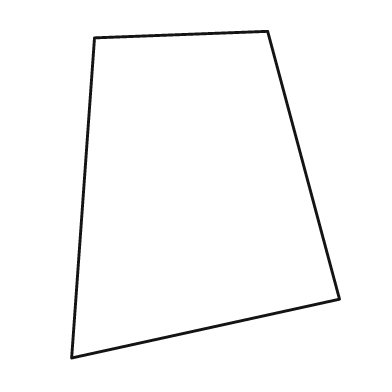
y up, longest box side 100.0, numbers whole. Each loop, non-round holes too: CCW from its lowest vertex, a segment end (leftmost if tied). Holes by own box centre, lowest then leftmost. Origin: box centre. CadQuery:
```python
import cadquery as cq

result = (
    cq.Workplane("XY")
    .moveTo(-41.0, -50.0)
    .lineTo(41.0, -32.0)
    .lineTo(19.0, 50.0)
    .lineTo(-34.0, 48.0)
    .close()
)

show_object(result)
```